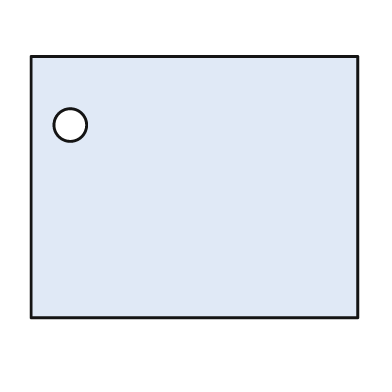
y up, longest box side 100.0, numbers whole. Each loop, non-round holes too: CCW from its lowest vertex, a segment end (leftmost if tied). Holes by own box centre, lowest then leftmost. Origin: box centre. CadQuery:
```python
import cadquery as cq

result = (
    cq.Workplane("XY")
    .moveTo(-50.0, -40.0)
    .lineTo(50.0, -40.0)
    .lineTo(50.0, 40.0)
    .lineTo(-50.0, 40.0)
    .close()
    .moveTo(-38.0, 19.0)
    .circle(5.0)
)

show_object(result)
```